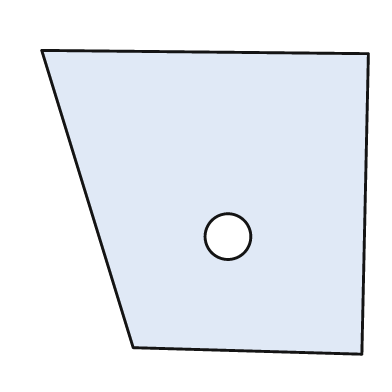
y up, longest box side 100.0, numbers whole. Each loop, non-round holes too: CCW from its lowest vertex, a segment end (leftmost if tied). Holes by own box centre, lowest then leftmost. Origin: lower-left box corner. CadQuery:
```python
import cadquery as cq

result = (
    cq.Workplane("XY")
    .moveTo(98.0, 0.0)
    .lineTo(100.0, 92.0)
    .lineTo(0.0, 93.0)
    .lineTo(28.0, 2.0)
    .close()
    .moveTo(57.0, 36.0)
    .circle(7.0)
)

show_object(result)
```